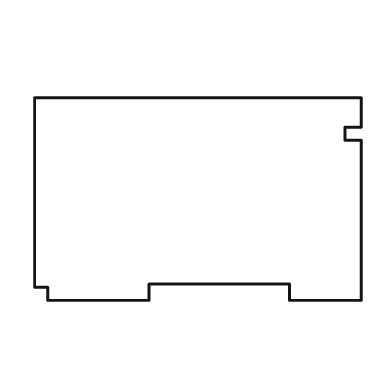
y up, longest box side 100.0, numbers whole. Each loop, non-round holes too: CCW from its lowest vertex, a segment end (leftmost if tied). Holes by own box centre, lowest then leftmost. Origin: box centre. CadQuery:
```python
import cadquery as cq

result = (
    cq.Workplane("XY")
    .moveTo(-46.0, -31.0)
    .lineTo(-15.0, -31.0)
    .lineTo(-15.0, -26.0)
    .lineTo(28.0, -26.0)
    .lineTo(28.0, -31.0)
    .lineTo(50.0, -31.0)
    .lineTo(50.0, 18.0)
    .lineTo(45.0, 18.0)
    .lineTo(45.0, 22.0)
    .lineTo(50.0, 22.0)
    .lineTo(50.0, 31.0)
    .lineTo(-50.0, 31.0)
    .lineTo(-50.0, -27.0)
    .lineTo(-46.0, -27.0)
    .close()
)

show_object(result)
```